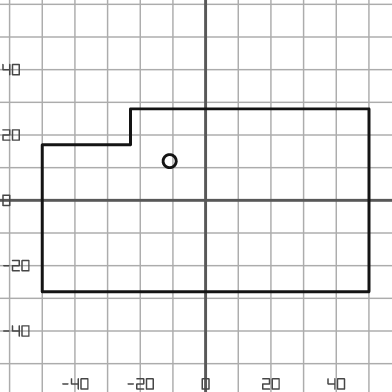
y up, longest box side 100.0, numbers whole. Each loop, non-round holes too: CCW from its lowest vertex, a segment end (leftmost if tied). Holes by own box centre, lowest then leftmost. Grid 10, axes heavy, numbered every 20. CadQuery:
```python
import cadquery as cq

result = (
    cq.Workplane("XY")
    .moveTo(-50.0, -28.0)
    .lineTo(50.0, -28.0)
    .lineTo(50.0, 28.0)
    .lineTo(-23.0, 28.0)
    .lineTo(-23.0, 17.0)
    .lineTo(-50.0, 17.0)
    .close()
    .moveTo(-11.0, 12.0)
    .circle(2.0)
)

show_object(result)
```